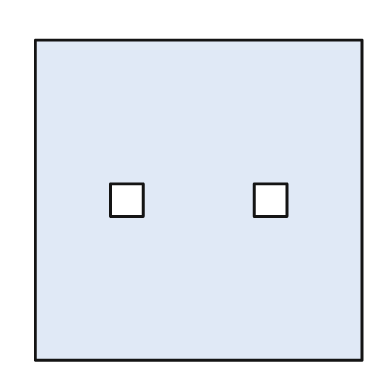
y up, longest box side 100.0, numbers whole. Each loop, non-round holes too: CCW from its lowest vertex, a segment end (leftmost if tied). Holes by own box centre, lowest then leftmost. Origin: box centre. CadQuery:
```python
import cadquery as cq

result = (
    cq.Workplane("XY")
    .moveTo(-50.0, -49.0)
    .lineTo(50.0, -49.0)
    .lineTo(50.0, 49.0)
    .lineTo(-50.0, 49.0)
    .close()
    .moveTo(-27.0, -5.0)
    .lineTo(-17.0, -5.0)
    .lineTo(-17.0, 5.0)
    .lineTo(-27.0, 5.0)
    .close()
    .moveTo(17.0, -5.0)
    .lineTo(27.0, -5.0)
    .lineTo(27.0, 5.0)
    .lineTo(17.0, 5.0)
    .close()
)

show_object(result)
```